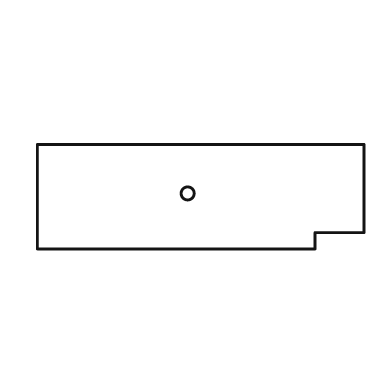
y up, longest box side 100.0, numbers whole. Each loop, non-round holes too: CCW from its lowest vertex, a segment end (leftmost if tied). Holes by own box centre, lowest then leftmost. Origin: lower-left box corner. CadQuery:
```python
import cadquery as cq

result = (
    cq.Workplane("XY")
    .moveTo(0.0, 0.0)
    .lineTo(85.0, 0.0)
    .lineTo(85.0, 5.0)
    .lineTo(100.0, 5.0)
    .lineTo(100.0, 32.0)
    .lineTo(0.0, 32.0)
    .close()
    .moveTo(46.0, 17.0)
    .circle(2.0)
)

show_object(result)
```